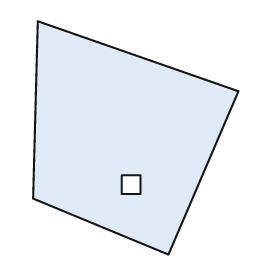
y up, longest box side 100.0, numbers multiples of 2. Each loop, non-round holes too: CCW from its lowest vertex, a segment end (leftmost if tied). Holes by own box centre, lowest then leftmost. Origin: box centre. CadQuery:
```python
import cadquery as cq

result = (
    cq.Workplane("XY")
    .moveTo(14.0, -50.0)
    .lineTo(44.0, 20.0)
    .lineTo(-42.0, 50.0)
    .lineTo(-44.0, -26.0)
    .close()
    .moveTo(-6.0, -24.0)
    .lineTo(2.0, -24.0)
    .lineTo(2.0, -16.0)
    .lineTo(-6.0, -16.0)
    .close()
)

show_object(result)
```